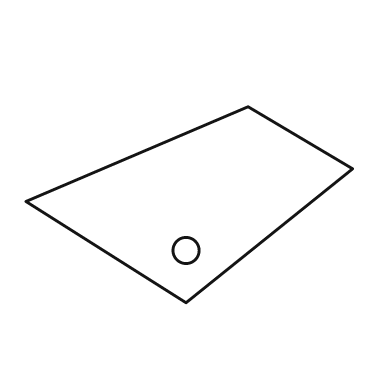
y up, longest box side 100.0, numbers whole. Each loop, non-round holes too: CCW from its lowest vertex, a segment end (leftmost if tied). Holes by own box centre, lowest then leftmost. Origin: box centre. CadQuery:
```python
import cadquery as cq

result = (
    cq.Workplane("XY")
    .moveTo(-1.0, -30.0)
    .lineTo(50.0, 11.0)
    .lineTo(18.0, 30.0)
    .lineTo(-50.0, 1.0)
    .close()
    .moveTo(-1.0, -14.0)
    .circle(4.0)
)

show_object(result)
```